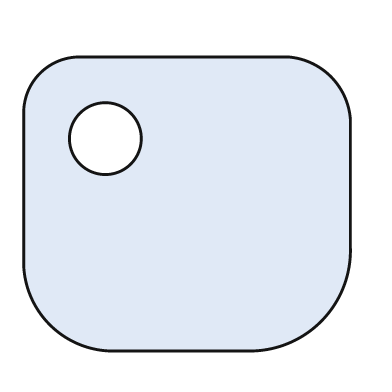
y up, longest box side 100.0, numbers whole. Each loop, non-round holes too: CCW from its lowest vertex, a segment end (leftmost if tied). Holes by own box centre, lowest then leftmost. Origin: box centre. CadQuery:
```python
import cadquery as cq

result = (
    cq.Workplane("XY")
    .moveTo(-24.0, -45.0)
    .lineTo(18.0, -45.0)
    .threePointArc((41.0, -36.0), (50.0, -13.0))
    .lineTo(50.0, 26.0)
    .threePointArc((44.0, 39.0), (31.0, 45.0))
    .lineTo(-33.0, 45.0)
    .threePointArc((-45.0, 40.0), (-50.0, 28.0))
    .lineTo(-50.0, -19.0)
    .threePointArc((-42.0, -37.0), (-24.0, -45.0))
    .close()
    .moveTo(-25.0, 20.0)
    .circle(11.0)
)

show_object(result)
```